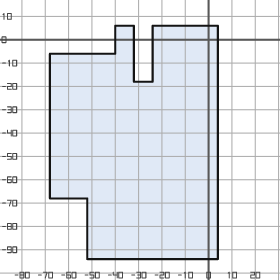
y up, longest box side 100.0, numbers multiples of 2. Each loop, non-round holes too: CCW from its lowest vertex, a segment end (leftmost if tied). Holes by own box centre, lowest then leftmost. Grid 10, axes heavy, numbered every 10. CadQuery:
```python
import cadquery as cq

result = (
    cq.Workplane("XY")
    .moveTo(-52.0, -94.0)
    .lineTo(4.0, -94.0)
    .lineTo(4.0, 6.0)
    .lineTo(-24.0, 6.0)
    .lineTo(-24.0, -18.0)
    .lineTo(-32.0, -18.0)
    .lineTo(-32.0, 6.0)
    .lineTo(-40.0, 6.0)
    .lineTo(-40.0, -6.0)
    .lineTo(-68.0, -6.0)
    .lineTo(-68.0, -68.0)
    .lineTo(-52.0, -68.0)
    .close()
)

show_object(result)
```